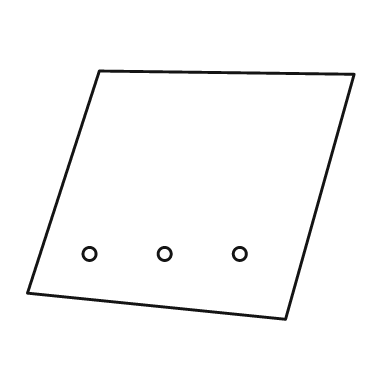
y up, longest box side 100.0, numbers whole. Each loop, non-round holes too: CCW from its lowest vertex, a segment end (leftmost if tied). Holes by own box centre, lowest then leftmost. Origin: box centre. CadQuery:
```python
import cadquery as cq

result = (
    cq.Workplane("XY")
    .moveTo(29.0, -38.0)
    .lineTo(50.0, 37.0)
    .lineTo(-28.0, 38.0)
    .lineTo(-50.0, -30.0)
    .close()
    .moveTo(-31.0, -18.0)
    .circle(2.0)
    .moveTo(-8.0, -18.0)
    .circle(2.0)
    .moveTo(15.0, -18.0)
    .circle(2.0)
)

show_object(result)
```